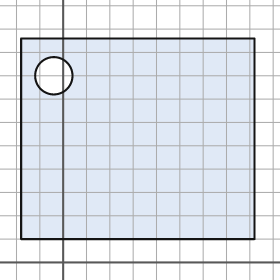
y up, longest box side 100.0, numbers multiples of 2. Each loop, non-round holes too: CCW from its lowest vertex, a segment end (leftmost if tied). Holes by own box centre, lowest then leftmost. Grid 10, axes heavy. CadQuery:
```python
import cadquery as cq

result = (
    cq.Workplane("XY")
    .moveTo(-18.0, 10.0)
    .lineTo(82.0, 10.0)
    .lineTo(82.0, 96.0)
    .lineTo(-18.0, 96.0)
    .close()
    .moveTo(-4.0, 80.0)
    .circle(8.0)
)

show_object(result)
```